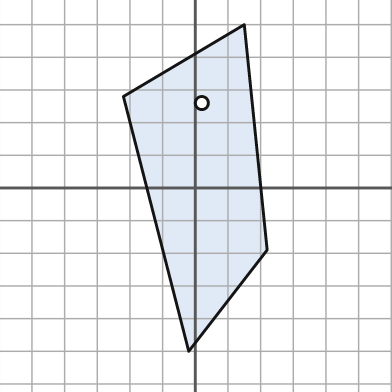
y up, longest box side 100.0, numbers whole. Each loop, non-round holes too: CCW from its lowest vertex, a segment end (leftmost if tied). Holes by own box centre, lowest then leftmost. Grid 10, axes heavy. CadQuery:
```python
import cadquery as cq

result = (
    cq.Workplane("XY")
    .moveTo(-2.0, -50.0)
    .lineTo(22.0, -19.0)
    .lineTo(15.0, 50.0)
    .lineTo(-22.0, 28.0)
    .close()
    .moveTo(2.0, 26.0)
    .circle(2.0)
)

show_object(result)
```